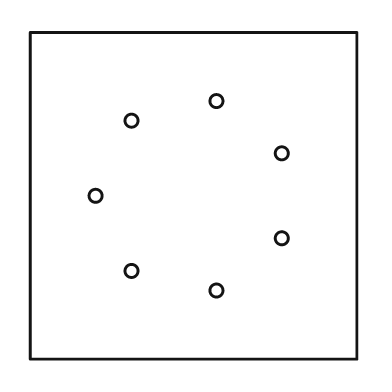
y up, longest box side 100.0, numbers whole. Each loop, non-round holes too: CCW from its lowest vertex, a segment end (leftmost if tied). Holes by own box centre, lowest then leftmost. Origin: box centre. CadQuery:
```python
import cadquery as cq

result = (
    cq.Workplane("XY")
    .moveTo(-50.0, -50.0)
    .lineTo(50.0, -50.0)
    .lineTo(50.0, 50.0)
    .lineTo(-50.0, 50.0)
    .close()
    .moveTo(7.0, -29.0)
    .circle(2.0)
    .moveTo(-19.0, -23.0)
    .circle(2.0)
    .moveTo(27.0, -13.0)
    .circle(2.0)
    .moveTo(-30.0, 0.0)
    .circle(2.0)
    .moveTo(27.0, 13.0)
    .circle(2.0)
    .moveTo(-19.0, 23.0)
    .circle(2.0)
    .moveTo(7.0, 29.0)
    .circle(2.0)
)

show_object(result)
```